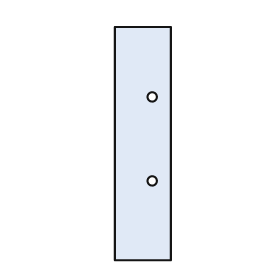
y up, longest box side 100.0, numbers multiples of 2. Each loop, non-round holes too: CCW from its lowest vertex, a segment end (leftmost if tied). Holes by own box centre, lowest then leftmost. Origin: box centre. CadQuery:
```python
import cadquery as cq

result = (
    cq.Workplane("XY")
    .moveTo(-12.0, -50.0)
    .lineTo(12.0, -50.0)
    .lineTo(12.0, 50.0)
    .lineTo(-12.0, 50.0)
    .close()
    .moveTo(4.0, -16.0)
    .circle(2.0)
    .moveTo(4.0, 20.0)
    .circle(2.0)
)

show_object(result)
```